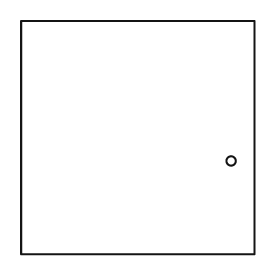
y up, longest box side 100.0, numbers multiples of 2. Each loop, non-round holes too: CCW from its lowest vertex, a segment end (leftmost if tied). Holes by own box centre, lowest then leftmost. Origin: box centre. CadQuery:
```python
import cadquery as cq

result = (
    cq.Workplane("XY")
    .moveTo(-50.0, -50.0)
    .lineTo(50.0, -50.0)
    .lineTo(50.0, 50.0)
    .lineTo(-50.0, 50.0)
    .close()
    .moveTo(40.0, -10.0)
    .circle(2.0)
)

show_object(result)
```